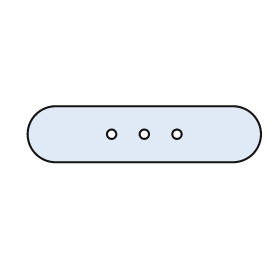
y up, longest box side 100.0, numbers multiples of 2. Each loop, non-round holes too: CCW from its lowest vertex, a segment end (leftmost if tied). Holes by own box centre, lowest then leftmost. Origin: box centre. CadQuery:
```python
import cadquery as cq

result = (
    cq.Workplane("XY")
    .moveTo(-38.0, -12.0)
    .lineTo(38.0, -12.0)
    .threePointArc((50.0, 0.0), (38.0, 12.0))
    .lineTo(-38.0, 12.0)
    .threePointArc((-50.0, 0.0), (-38.0, -12.0))
    .close()
    .moveTo(-14.0, 0.0)
    .circle(2.0)
    .moveTo(0.0, 0.0)
    .circle(2.0)
    .moveTo(14.0, 0.0)
    .circle(2.0)
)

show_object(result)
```